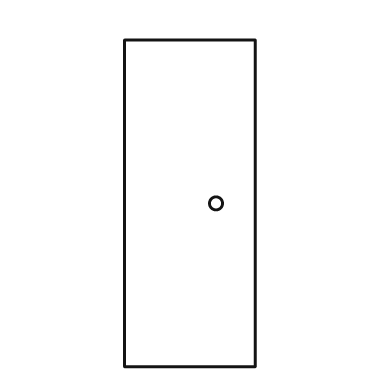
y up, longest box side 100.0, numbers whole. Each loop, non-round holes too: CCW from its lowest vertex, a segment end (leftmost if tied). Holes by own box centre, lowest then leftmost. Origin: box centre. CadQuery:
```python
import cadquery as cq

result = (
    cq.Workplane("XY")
    .moveTo(-20.0, -50.0)
    .lineTo(20.0, -50.0)
    .lineTo(20.0, 50.0)
    .lineTo(-20.0, 50.0)
    .close()
    .moveTo(8.0, 0.0)
    .circle(2.0)
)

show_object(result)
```